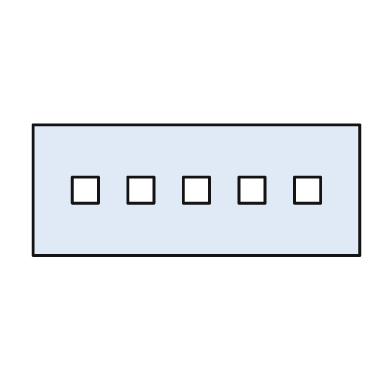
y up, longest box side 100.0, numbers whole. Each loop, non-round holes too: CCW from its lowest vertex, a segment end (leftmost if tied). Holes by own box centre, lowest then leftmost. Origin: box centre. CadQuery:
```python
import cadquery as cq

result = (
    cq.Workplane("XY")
    .moveTo(-50.0, -20.0)
    .lineTo(50.0, -20.0)
    .lineTo(50.0, 20.0)
    .lineTo(-50.0, 20.0)
    .close()
    .moveTo(-38.0, -4.0)
    .lineTo(-30.0, -4.0)
    .lineTo(-30.0, 4.0)
    .lineTo(-38.0, 4.0)
    .close()
    .moveTo(-21.0, -4.0)
    .lineTo(-13.0, -4.0)
    .lineTo(-13.0, 4.0)
    .lineTo(-21.0, 4.0)
    .close()
    .moveTo(-4.0, -4.0)
    .lineTo(4.0, -4.0)
    .lineTo(4.0, 4.0)
    .lineTo(-4.0, 4.0)
    .close()
    .moveTo(13.0, -4.0)
    .lineTo(21.0, -4.0)
    .lineTo(21.0, 4.0)
    .lineTo(13.0, 4.0)
    .close()
    .moveTo(30.0, -4.0)
    .lineTo(38.0, -4.0)
    .lineTo(38.0, 4.0)
    .lineTo(30.0, 4.0)
    .close()
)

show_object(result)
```